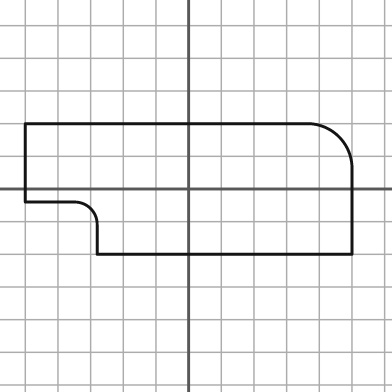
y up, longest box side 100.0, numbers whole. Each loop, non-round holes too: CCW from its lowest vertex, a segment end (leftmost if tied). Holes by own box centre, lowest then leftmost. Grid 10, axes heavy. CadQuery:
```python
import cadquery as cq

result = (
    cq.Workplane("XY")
    .moveTo(-28.0, -20.0)
    .lineTo(50.0, -20.0)
    .lineTo(50.0, 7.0)
    .threePointArc((46.0, 16.0), (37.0, 20.0))
    .lineTo(-50.0, 20.0)
    .lineTo(-50.0, -4.0)
    .lineTo(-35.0, -4.0)
    .threePointArc((-30.0, -6.0), (-28.0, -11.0))
    .close()
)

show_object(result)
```